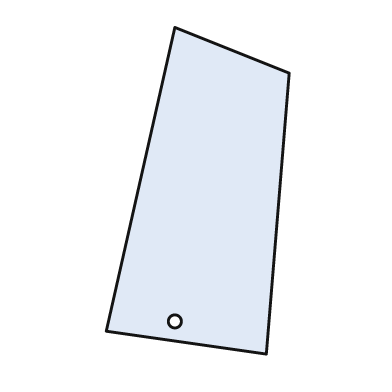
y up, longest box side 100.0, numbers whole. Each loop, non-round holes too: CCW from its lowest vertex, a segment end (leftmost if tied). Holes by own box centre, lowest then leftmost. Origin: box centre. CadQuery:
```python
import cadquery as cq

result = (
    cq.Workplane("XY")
    .moveTo(21.0, -50.0)
    .lineTo(28.0, 36.0)
    .lineTo(-7.0, 50.0)
    .lineTo(-28.0, -43.0)
    .close()
    .moveTo(-7.0, -40.0)
    .circle(2.0)
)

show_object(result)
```